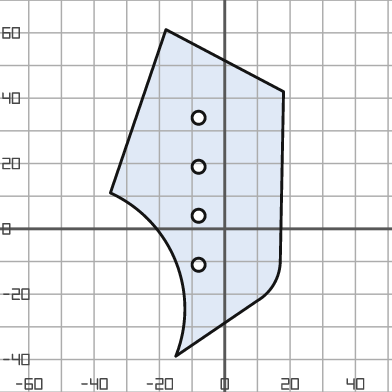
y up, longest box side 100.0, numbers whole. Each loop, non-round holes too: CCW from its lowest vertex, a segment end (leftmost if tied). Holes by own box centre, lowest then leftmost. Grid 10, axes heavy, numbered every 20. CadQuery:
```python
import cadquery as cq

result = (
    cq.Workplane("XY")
    .moveTo(-15.0, -39.0)
    .lineTo(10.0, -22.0)
    .threePointArc((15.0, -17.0), (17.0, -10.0))
    .lineTo(18.0, 42.0)
    .lineTo(-18.0, 61.0)
    .lineTo(-35.0, 11.0)
    .threePointArc((-15.0, -10.0), (-15.0, -39.0))
    .close()
    .moveTo(-8.0, -11.0)
    .circle(2.0)
    .moveTo(-8.0, 4.0)
    .circle(2.0)
    .moveTo(-8.0, 19.0)
    .circle(2.0)
    .moveTo(-8.0, 34.0)
    .circle(2.0)
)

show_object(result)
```